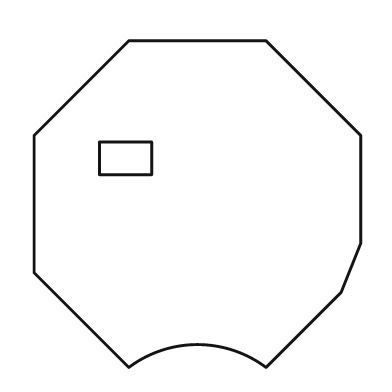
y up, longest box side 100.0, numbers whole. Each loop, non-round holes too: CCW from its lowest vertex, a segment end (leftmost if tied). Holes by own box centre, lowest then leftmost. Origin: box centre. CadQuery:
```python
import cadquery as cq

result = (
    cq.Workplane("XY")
    .moveTo(-21.0, -50.0)
    .threePointArc((0.0, -43.0), (21.0, -50.0))
    .lineTo(44.0, -27.0)
    .lineTo(50.0, -12.0)
    .lineTo(50.0, 21.0)
    .lineTo(21.0, 50.0)
    .lineTo(-21.0, 50.0)
    .lineTo(-50.0, 21.0)
    .lineTo(-50.0, -21.0)
    .close()
    .moveTo(-30.0, 9.0)
    .lineTo(-14.0, 9.0)
    .lineTo(-14.0, 19.0)
    .lineTo(-30.0, 19.0)
    .close()
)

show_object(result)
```